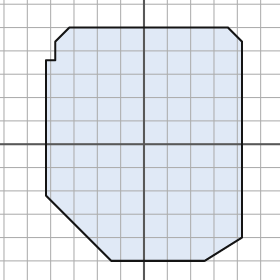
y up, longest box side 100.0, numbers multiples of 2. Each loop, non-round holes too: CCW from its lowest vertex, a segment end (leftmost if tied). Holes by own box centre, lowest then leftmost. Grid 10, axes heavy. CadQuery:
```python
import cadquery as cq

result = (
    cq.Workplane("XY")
    .moveTo(-14.0, -50.0)
    .lineTo(26.0, -50.0)
    .lineTo(42.0, -40.0)
    .lineTo(42.0, 44.0)
    .lineTo(36.0, 50.0)
    .lineTo(-32.0, 50.0)
    .lineTo(-38.0, 44.0)
    .lineTo(-38.0, 36.0)
    .lineTo(-42.0, 36.0)
    .lineTo(-42.0, -22.0)
    .close()
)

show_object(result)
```